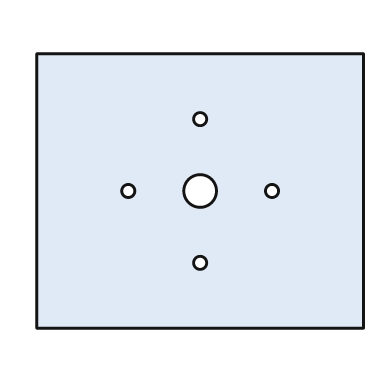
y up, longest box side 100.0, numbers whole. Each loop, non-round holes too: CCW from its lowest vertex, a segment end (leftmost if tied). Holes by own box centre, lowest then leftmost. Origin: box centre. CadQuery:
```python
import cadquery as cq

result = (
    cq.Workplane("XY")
    .moveTo(-50.0, -42.0)
    .lineTo(50.0, -42.0)
    .lineTo(50.0, 42.0)
    .lineTo(-50.0, 42.0)
    .close()
    .moveTo(0.0, -22.0)
    .circle(2.0)
    .moveTo(-22.0, 0.0)
    .circle(2.0)
    .moveTo(0.0, 0.0)
    .circle(5.0)
    .moveTo(22.0, 0.0)
    .circle(2.0)
    .moveTo(0.0, 22.0)
    .circle(2.0)
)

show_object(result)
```